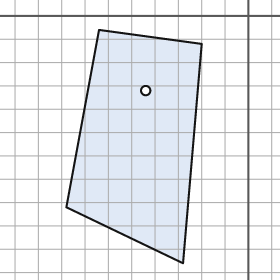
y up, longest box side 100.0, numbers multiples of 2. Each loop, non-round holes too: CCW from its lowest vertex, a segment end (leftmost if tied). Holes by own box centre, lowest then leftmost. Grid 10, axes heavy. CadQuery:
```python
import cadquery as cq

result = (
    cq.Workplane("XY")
    .moveTo(-28.0, -106.0)
    .lineTo(-20.0, -12.0)
    .lineTo(-64.0, -6.0)
    .lineTo(-78.0, -82.0)
    .close()
    .moveTo(-44.0, -32.0)
    .circle(2.0)
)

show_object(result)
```